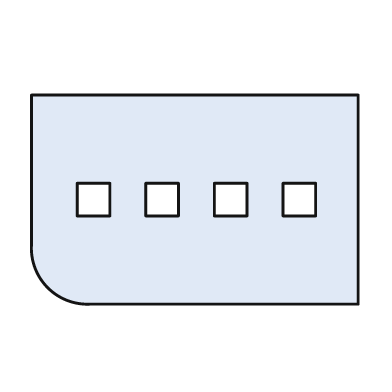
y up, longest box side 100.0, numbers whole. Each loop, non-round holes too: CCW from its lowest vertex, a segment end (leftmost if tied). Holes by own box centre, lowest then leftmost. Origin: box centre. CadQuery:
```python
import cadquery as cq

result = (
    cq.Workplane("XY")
    .moveTo(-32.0, -32.0)
    .lineTo(50.0, -32.0)
    .lineTo(50.0, 32.0)
    .lineTo(-50.0, 32.0)
    .lineTo(-50.0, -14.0)
    .threePointArc((-45.0, -27.0), (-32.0, -32.0))
    .close()
    .moveTo(-36.0, -5.0)
    .lineTo(-26.0, -5.0)
    .lineTo(-26.0, 5.0)
    .lineTo(-36.0, 5.0)
    .close()
    .moveTo(-15.0, -5.0)
    .lineTo(-5.0, -5.0)
    .lineTo(-5.0, 5.0)
    .lineTo(-15.0, 5.0)
    .close()
    .moveTo(6.0, -5.0)
    .lineTo(16.0, -5.0)
    .lineTo(16.0, 5.0)
    .lineTo(6.0, 5.0)
    .close()
    .moveTo(27.0, -5.0)
    .lineTo(37.0, -5.0)
    .lineTo(37.0, 5.0)
    .lineTo(27.0, 5.0)
    .close()
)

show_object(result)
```